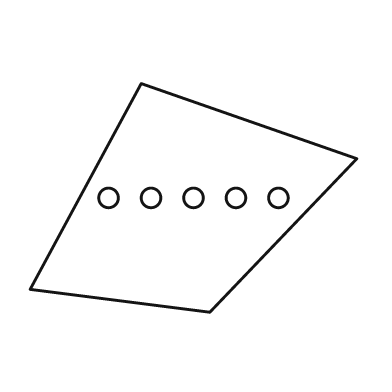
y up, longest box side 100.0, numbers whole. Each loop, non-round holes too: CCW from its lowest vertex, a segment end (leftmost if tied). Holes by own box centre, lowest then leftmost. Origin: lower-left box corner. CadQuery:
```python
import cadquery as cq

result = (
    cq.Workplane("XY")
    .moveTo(55.0, 0.0)
    .lineTo(100.0, 47.0)
    .lineTo(34.0, 70.0)
    .lineTo(0.0, 7.0)
    .close()
    .moveTo(24.0, 35.0)
    .circle(3.0)
    .moveTo(37.0, 35.0)
    .circle(3.0)
    .moveTo(50.0, 35.0)
    .circle(3.0)
    .moveTo(63.0, 35.0)
    .circle(3.0)
    .moveTo(76.0, 35.0)
    .circle(3.0)
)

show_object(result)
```